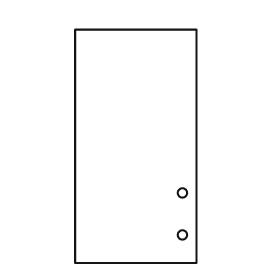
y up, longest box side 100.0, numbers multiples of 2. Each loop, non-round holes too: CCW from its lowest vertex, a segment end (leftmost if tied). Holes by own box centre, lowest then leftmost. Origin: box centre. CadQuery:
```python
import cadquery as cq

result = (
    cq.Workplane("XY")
    .moveTo(-26.0, -50.0)
    .lineTo(26.0, -50.0)
    .lineTo(26.0, 50.0)
    .lineTo(-26.0, 50.0)
    .close()
    .moveTo(20.0, -38.0)
    .circle(2.0)
    .moveTo(20.0, -20.0)
    .circle(2.0)
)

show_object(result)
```